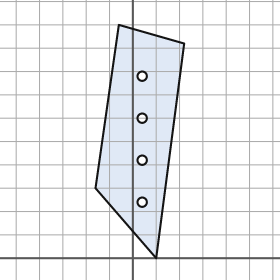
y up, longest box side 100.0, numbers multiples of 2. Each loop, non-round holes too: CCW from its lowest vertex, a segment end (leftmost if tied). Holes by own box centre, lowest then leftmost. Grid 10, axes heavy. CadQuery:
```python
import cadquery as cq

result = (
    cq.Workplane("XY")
    .moveTo(10.0, 0.0)
    .lineTo(22.0, 92.0)
    .lineTo(-6.0, 100.0)
    .lineTo(-16.0, 30.0)
    .close()
    .moveTo(4.0, 24.0)
    .circle(2.0)
    .moveTo(4.0, 42.0)
    .circle(2.0)
    .moveTo(4.0, 60.0)
    .circle(2.0)
    .moveTo(4.0, 78.0)
    .circle(2.0)
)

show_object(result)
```